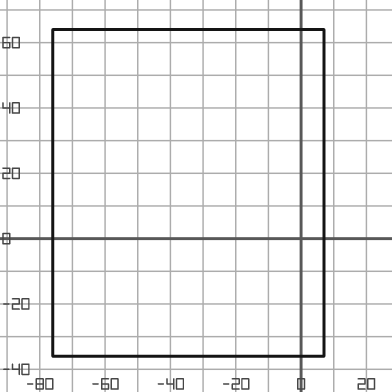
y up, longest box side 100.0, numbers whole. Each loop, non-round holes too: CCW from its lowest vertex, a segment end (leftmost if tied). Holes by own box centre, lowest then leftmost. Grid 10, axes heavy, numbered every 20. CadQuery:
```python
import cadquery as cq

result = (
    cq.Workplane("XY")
    .moveTo(-76.0, -36.0)
    .lineTo(7.0, -36.0)
    .lineTo(7.0, 64.0)
    .lineTo(-76.0, 64.0)
    .close()
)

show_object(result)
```